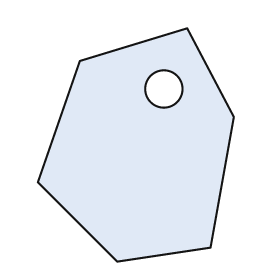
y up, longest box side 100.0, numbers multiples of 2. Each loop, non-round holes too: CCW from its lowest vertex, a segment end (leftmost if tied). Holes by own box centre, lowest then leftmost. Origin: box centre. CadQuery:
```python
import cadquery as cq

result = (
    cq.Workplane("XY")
    .moveTo(-8.0, -50.0)
    .lineTo(32.0, -44.0)
    .lineTo(42.0, 12.0)
    .lineTo(22.0, 50.0)
    .lineTo(-24.0, 36.0)
    .lineTo(-42.0, -16.0)
    .close()
    .moveTo(12.0, 24.0)
    .circle(8.0)
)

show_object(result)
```